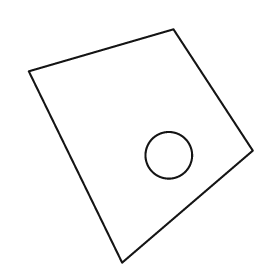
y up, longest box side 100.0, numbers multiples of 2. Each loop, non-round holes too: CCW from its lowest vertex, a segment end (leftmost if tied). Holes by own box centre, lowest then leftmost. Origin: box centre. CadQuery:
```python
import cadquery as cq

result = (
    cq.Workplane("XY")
    .moveTo(-8.0, -50.0)
    .lineTo(48.0, -2.0)
    .lineTo(14.0, 50.0)
    .lineTo(-48.0, 32.0)
    .close()
    .moveTo(12.0, -4.0)
    .circle(10.0)
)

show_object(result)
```